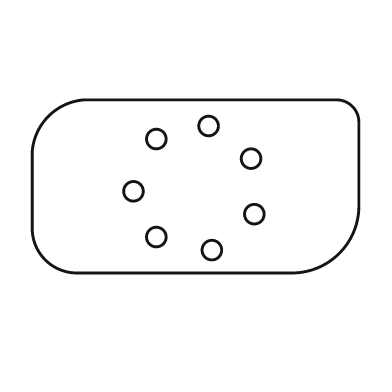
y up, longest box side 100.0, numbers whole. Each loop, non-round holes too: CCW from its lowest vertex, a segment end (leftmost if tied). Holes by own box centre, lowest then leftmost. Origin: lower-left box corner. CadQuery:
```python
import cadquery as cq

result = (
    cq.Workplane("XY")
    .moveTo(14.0, 0.0)
    .lineTo(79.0, 0.0)
    .threePointArc((94.0, 6.0), (100.0, 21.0))
    .lineTo(100.0, 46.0)
    .threePointArc((98.0, 51.0), (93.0, 53.0))
    .lineTo(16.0, 53.0)
    .threePointArc((5.0, 48.0), (0.0, 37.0))
    .lineTo(0.0, 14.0)
    .threePointArc((4.0, 4.0), (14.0, 0.0))
    .close()
    .moveTo(55.0, 7.0)
    .circle(3.0)
    .moveTo(38.0, 11.0)
    .circle(3.0)
    .moveTo(68.0, 18.0)
    .circle(3.0)
    .moveTo(31.0, 25.0)
    .circle(3.0)
    .moveTo(67.0, 35.0)
    .circle(3.0)
    .moveTo(38.0, 41.0)
    .circle(3.0)
    .moveTo(54.0, 45.0)
    .circle(3.0)
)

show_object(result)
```